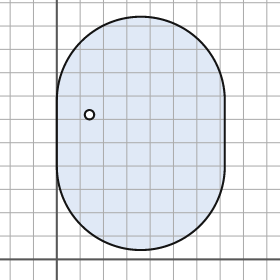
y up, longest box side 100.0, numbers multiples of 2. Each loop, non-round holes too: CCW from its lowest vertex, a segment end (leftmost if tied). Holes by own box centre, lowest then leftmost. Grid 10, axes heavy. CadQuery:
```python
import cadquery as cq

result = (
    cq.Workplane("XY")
    .moveTo(0.0, 40.0)
    .threePointArc((36.0, 4.0), (72.0, 40.0))
    .lineTo(72.0, 68.0)
    .threePointArc((36.0, 104.0), (0.0, 68.0))
    .close()
    .moveTo(14.0, 62.0)
    .circle(2.0)
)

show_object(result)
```